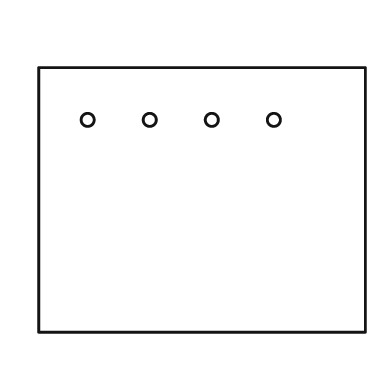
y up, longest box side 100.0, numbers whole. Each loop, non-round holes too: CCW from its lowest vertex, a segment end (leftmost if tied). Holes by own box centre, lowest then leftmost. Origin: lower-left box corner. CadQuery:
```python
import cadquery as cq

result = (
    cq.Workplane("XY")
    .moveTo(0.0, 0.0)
    .lineTo(100.0, 0.0)
    .lineTo(100.0, 81.0)
    .lineTo(0.0, 81.0)
    .close()
    .moveTo(15.0, 65.0)
    .circle(2.0)
    .moveTo(34.0, 65.0)
    .circle(2.0)
    .moveTo(53.0, 65.0)
    .circle(2.0)
    .moveTo(72.0, 65.0)
    .circle(2.0)
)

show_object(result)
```